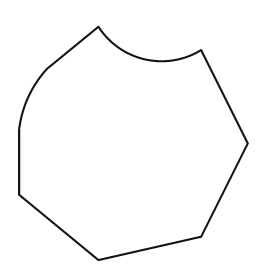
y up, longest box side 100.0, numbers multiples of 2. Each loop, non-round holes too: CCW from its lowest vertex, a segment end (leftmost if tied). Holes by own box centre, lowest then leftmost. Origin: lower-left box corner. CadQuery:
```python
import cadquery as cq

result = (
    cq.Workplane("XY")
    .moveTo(34.0, 0.0)
    .lineTo(78.0, 10.0)
    .lineTo(98.0, 50.0)
    .lineTo(78.0, 90.0)
    .threePointArc((54.0, 86.0), (34.0, 100.0))
    .lineTo(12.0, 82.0)
    .threePointArc((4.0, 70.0), (0.0, 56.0))
    .lineTo(0.0, 28.0)
    .close()
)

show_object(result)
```